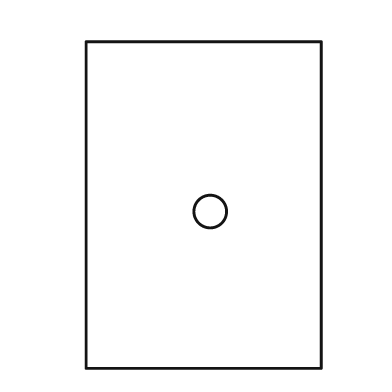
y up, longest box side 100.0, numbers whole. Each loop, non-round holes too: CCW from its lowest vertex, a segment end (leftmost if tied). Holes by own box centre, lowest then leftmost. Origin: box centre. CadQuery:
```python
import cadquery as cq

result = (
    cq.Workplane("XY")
    .moveTo(-36.0, -50.0)
    .lineTo(36.0, -50.0)
    .lineTo(36.0, 50.0)
    .lineTo(-36.0, 50.0)
    .close()
    .moveTo(2.0, -2.0)
    .circle(5.0)
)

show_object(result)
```